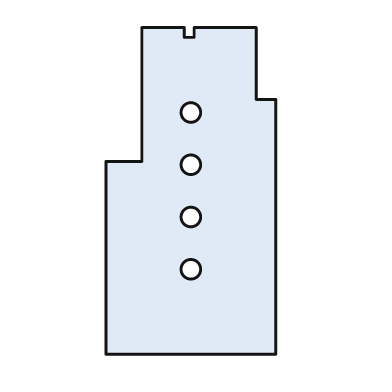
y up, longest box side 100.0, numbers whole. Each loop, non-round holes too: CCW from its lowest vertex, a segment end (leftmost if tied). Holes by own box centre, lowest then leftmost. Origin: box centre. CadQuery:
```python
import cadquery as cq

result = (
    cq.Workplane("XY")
    .moveTo(-26.0, -50.0)
    .lineTo(26.0, -50.0)
    .lineTo(26.0, 28.0)
    .lineTo(20.0, 28.0)
    .lineTo(20.0, 50.0)
    .lineTo(1.0, 50.0)
    .lineTo(1.0, 47.0)
    .lineTo(-2.0, 47.0)
    .lineTo(-2.0, 50.0)
    .lineTo(-15.0, 50.0)
    .lineTo(-15.0, 9.0)
    .lineTo(-26.0, 9.0)
    .close()
    .moveTo(0.0, -24.0)
    .circle(3.0)
    .moveTo(0.0, -8.0)
    .circle(3.0)
    .moveTo(0.0, 8.0)
    .circle(3.0)
    .moveTo(0.0, 24.0)
    .circle(3.0)
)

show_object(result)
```